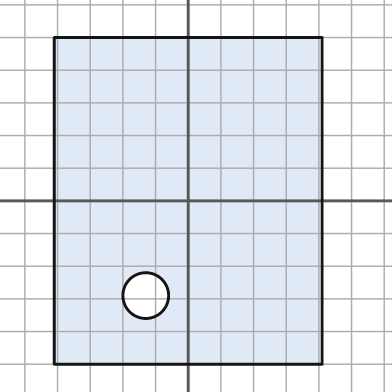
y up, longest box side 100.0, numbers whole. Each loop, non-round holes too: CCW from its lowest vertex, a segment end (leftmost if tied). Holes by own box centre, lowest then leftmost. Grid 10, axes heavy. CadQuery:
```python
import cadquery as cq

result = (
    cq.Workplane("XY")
    .moveTo(-41.0, -50.0)
    .lineTo(41.0, -50.0)
    .lineTo(41.0, 50.0)
    .lineTo(-41.0, 50.0)
    .close()
    .moveTo(-13.0, -29.0)
    .circle(7.0)
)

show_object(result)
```